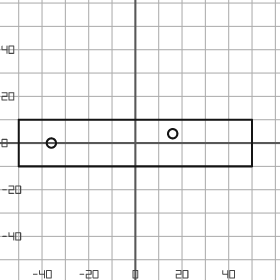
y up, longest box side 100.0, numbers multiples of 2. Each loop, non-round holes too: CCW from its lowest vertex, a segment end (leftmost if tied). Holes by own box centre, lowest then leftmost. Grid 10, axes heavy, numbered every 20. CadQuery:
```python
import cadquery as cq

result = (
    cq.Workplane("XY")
    .moveTo(-50.0, -10.0)
    .lineTo(50.0, -10.0)
    .lineTo(50.0, 10.0)
    .lineTo(-50.0, 10.0)
    .close()
    .moveTo(-36.0, 0.0)
    .circle(2.0)
    .moveTo(16.0, 4.0)
    .circle(2.0)
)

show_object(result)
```